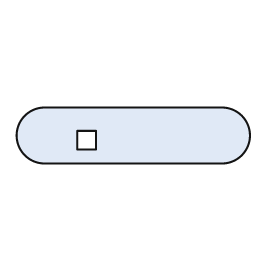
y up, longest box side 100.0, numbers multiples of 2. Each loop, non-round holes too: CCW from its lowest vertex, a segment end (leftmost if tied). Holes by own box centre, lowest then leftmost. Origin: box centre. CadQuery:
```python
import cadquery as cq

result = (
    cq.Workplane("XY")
    .moveTo(-38.0, -12.0)
    .lineTo(38.0, -12.0)
    .threePointArc((50.0, 0.0), (38.0, 12.0))
    .lineTo(-38.0, 12.0)
    .threePointArc((-50.0, 0.0), (-38.0, -12.0))
    .close()
    .moveTo(-24.0, -6.0)
    .lineTo(-16.0, -6.0)
    .lineTo(-16.0, 2.0)
    .lineTo(-24.0, 2.0)
    .close()
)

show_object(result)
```